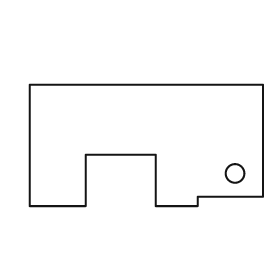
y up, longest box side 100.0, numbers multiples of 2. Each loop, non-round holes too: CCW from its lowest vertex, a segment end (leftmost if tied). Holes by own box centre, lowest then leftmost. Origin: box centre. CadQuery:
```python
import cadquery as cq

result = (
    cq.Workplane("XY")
    .moveTo(-50.0, -26.0)
    .lineTo(-26.0, -26.0)
    .lineTo(-26.0, -4.0)
    .lineTo(4.0, -4.0)
    .lineTo(4.0, -26.0)
    .lineTo(22.0, -26.0)
    .lineTo(22.0, -22.0)
    .lineTo(50.0, -22.0)
    .lineTo(50.0, 26.0)
    .lineTo(-50.0, 26.0)
    .close()
    .moveTo(38.0, -12.0)
    .circle(4.0)
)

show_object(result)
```